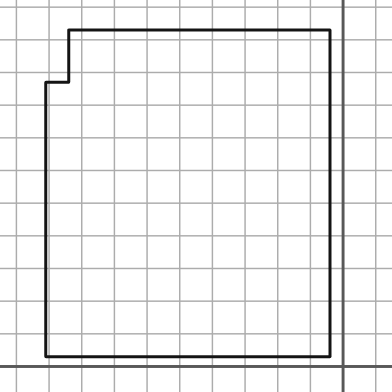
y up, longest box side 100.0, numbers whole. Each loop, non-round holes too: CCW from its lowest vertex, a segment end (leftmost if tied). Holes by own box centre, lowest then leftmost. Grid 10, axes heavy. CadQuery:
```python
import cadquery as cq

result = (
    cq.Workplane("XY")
    .moveTo(-91.0, 3.0)
    .lineTo(-4.0, 3.0)
    .lineTo(-4.0, 103.0)
    .lineTo(-84.0, 103.0)
    .lineTo(-84.0, 87.0)
    .lineTo(-91.0, 87.0)
    .close()
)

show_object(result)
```